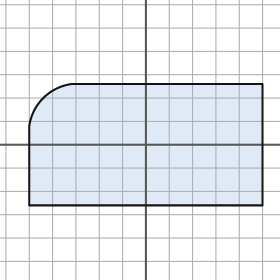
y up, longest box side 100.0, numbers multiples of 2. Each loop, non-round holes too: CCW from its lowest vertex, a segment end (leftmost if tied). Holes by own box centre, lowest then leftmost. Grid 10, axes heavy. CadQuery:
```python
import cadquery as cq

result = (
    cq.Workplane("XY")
    .moveTo(-50.0, -26.0)
    .lineTo(50.0, -26.0)
    .lineTo(50.0, 26.0)
    .lineTo(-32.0, 26.0)
    .threePointArc((-44.0, 20.0), (-50.0, 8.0))
    .close()
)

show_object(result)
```